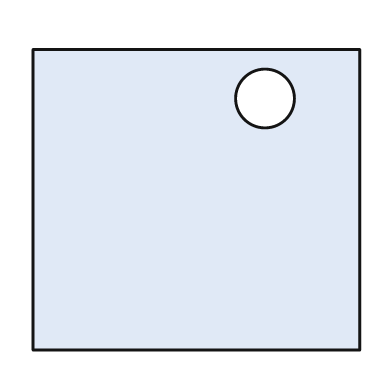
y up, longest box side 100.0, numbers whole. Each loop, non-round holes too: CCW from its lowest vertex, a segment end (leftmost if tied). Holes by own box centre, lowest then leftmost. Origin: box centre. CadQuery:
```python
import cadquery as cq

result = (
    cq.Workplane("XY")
    .moveTo(-50.0, -46.0)
    .lineTo(50.0, -46.0)
    .lineTo(50.0, 46.0)
    .lineTo(-50.0, 46.0)
    .close()
    .moveTo(21.0, 31.0)
    .circle(9.0)
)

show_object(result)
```